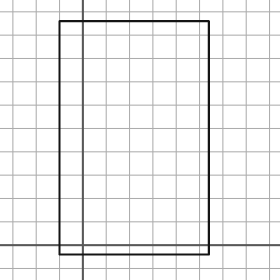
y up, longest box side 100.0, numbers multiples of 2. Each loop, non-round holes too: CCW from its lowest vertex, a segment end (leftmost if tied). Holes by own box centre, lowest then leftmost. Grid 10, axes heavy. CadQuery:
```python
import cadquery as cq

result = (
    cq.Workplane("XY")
    .moveTo(-10.0, -4.0)
    .lineTo(54.0, -4.0)
    .lineTo(54.0, 96.0)
    .lineTo(-10.0, 96.0)
    .close()
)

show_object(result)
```